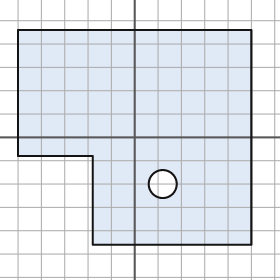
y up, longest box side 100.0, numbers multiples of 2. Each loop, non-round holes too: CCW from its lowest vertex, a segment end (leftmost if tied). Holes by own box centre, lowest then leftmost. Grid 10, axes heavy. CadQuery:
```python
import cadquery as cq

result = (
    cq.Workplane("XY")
    .moveTo(-18.0, -46.0)
    .lineTo(50.0, -46.0)
    .lineTo(50.0, 46.0)
    .lineTo(-50.0, 46.0)
    .lineTo(-50.0, -8.0)
    .lineTo(-18.0, -8.0)
    .close()
    .moveTo(12.0, -20.0)
    .circle(6.0)
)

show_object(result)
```